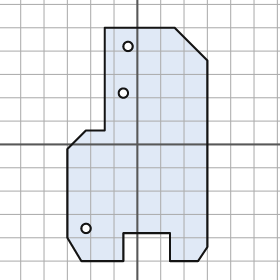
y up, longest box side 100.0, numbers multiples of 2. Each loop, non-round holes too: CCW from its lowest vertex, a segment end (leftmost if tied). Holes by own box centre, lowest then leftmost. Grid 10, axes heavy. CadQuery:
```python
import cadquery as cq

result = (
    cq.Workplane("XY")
    .moveTo(-24.0, -50.0)
    .lineTo(-6.0, -50.0)
    .lineTo(-6.0, -38.0)
    .lineTo(14.0, -38.0)
    .lineTo(14.0, -50.0)
    .lineTo(26.0, -50.0)
    .lineTo(30.0, -44.0)
    .lineTo(30.0, 36.0)
    .lineTo(16.0, 50.0)
    .lineTo(-14.0, 50.0)
    .lineTo(-14.0, 6.0)
    .lineTo(-22.0, 6.0)
    .lineTo(-30.0, -2.0)
    .lineTo(-30.0, -40.0)
    .close()
    .moveTo(-22.0, -36.0)
    .circle(2.0)
    .moveTo(-6.0, 22.0)
    .circle(2.0)
    .moveTo(-4.0, 42.0)
    .circle(2.0)
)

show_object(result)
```